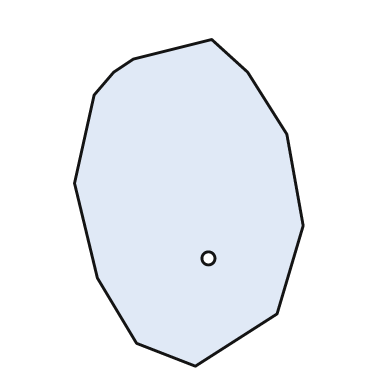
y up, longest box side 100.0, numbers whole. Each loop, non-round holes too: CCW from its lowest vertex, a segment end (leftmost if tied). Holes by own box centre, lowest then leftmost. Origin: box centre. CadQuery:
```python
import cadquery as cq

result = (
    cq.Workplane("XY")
    .moveTo(2.0, -50.0)
    .lineTo(27.0, -34.0)
    .lineTo(35.0, -7.0)
    .lineTo(30.0, 21.0)
    .lineTo(18.0, 40.0)
    .lineTo(7.0, 50.0)
    .lineTo(-17.0, 44.0)
    .lineTo(-23.0, 40.0)
    .lineTo(-29.0, 33.0)
    .lineTo(-35.0, 6.0)
    .lineTo(-28.0, -23.0)
    .lineTo(-16.0, -43.0)
    .close()
    .moveTo(6.0, -17.0)
    .circle(2.0)
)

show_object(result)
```